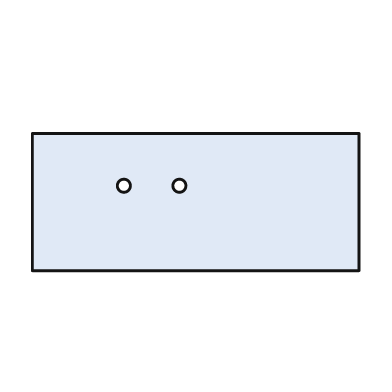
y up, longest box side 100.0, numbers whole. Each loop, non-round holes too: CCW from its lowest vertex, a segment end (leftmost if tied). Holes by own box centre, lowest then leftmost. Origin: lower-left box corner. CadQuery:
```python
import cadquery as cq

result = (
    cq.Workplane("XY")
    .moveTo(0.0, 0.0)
    .lineTo(100.0, 0.0)
    .lineTo(100.0, 42.0)
    .lineTo(0.0, 42.0)
    .close()
    .moveTo(28.0, 26.0)
    .circle(2.0)
    .moveTo(45.0, 26.0)
    .circle(2.0)
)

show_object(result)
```